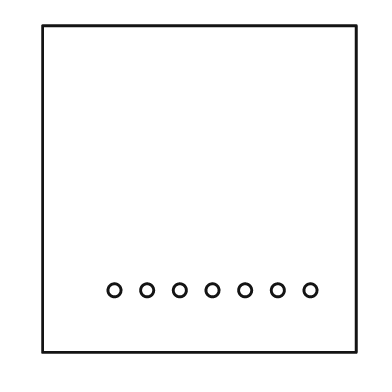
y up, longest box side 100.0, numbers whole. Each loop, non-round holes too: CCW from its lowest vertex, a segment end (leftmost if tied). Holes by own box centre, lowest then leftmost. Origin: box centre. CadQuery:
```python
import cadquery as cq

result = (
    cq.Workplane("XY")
    .moveTo(-48.0, -50.0)
    .lineTo(48.0, -50.0)
    .lineTo(48.0, 50.0)
    .lineTo(-48.0, 50.0)
    .close()
    .moveTo(-26.0, -31.0)
    .circle(2.0)
    .moveTo(-16.0, -31.0)
    .circle(2.0)
    .moveTo(-6.0, -31.0)
    .circle(2.0)
    .moveTo(4.0, -31.0)
    .circle(2.0)
    .moveTo(14.0, -31.0)
    .circle(2.0)
    .moveTo(24.0, -31.0)
    .circle(2.0)
    .moveTo(34.0, -31.0)
    .circle(2.0)
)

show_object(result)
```